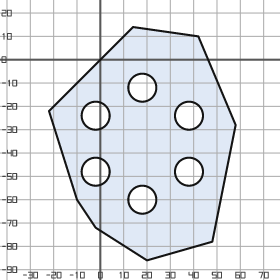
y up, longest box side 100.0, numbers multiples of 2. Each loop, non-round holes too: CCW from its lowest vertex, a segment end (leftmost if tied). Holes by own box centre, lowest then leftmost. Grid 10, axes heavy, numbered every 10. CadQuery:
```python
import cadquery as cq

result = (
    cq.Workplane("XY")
    .moveTo(20.0, -86.0)
    .lineTo(48.0, -78.0)
    .lineTo(58.0, -28.0)
    .lineTo(42.0, 10.0)
    .lineTo(14.0, 14.0)
    .lineTo(-22.0, -22.0)
    .lineTo(-10.0, -60.0)
    .lineTo(-2.0, -72.0)
    .close()
    .moveTo(18.0, -60.0)
    .circle(6.0)
    .moveTo(-2.0, -48.0)
    .circle(6.0)
    .moveTo(38.0, -48.0)
    .circle(6.0)
    .moveTo(-2.0, -24.0)
    .circle(6.0)
    .moveTo(38.0, -24.0)
    .circle(6.0)
    .moveTo(18.0, -12.0)
    .circle(6.0)
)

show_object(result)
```